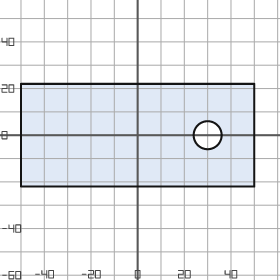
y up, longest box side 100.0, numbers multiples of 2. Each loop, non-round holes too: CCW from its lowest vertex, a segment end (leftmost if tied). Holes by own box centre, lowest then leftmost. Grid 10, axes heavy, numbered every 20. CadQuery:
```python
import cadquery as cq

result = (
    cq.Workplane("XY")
    .moveTo(-50.0, -22.0)
    .lineTo(50.0, -22.0)
    .lineTo(50.0, 22.0)
    .lineTo(-50.0, 22.0)
    .close()
    .moveTo(30.0, 0.0)
    .circle(6.0)
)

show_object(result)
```